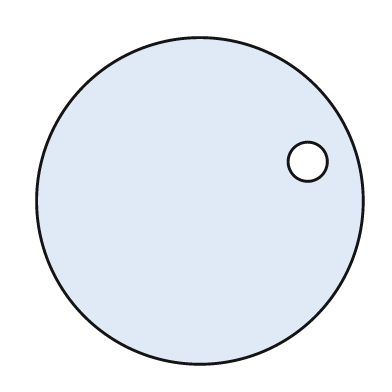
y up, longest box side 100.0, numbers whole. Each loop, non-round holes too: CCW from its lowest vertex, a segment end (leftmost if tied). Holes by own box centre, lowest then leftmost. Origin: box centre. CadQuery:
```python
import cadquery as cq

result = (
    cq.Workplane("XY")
    .moveTo(0.0, 0.0)
    .circle(50.0)
    .moveTo(33.0, 12.0)
    .circle(6.0)
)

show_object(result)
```